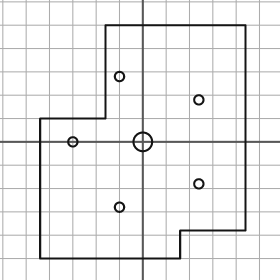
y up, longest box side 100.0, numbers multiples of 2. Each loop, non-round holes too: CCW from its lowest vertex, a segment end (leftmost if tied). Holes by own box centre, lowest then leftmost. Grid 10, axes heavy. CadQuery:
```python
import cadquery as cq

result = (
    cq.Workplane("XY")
    .moveTo(-44.0, -50.0)
    .lineTo(16.0, -50.0)
    .lineTo(16.0, -38.0)
    .lineTo(44.0, -38.0)
    .lineTo(44.0, 50.0)
    .lineTo(-16.0, 50.0)
    .lineTo(-16.0, 10.0)
    .lineTo(-44.0, 10.0)
    .close()
    .moveTo(-10.0, -28.0)
    .circle(2.0)
    .moveTo(24.0, -18.0)
    .circle(2.0)
    .moveTo(-30.0, 0.0)
    .circle(2.0)
    .moveTo(0.0, 0.0)
    .circle(4.0)
    .moveTo(24.0, 18.0)
    .circle(2.0)
    .moveTo(-10.0, 28.0)
    .circle(2.0)
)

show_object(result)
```